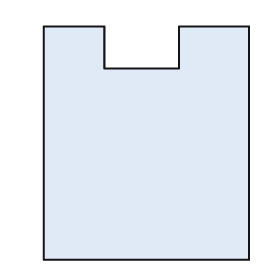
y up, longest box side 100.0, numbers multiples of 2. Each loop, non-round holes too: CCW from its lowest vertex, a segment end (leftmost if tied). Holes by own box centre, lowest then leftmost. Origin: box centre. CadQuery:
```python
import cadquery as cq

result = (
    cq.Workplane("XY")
    .moveTo(-44.0, -50.0)
    .lineTo(44.0, -50.0)
    .lineTo(44.0, 50.0)
    .lineTo(14.0, 50.0)
    .lineTo(14.0, 32.0)
    .lineTo(-18.0, 32.0)
    .lineTo(-18.0, 50.0)
    .lineTo(-44.0, 50.0)
    .close()
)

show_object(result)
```